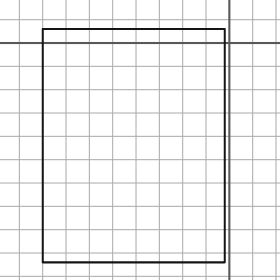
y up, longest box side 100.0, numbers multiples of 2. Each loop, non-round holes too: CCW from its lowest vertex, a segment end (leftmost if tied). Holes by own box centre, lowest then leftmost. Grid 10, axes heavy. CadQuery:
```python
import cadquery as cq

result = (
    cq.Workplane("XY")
    .moveTo(-80.0, -94.0)
    .lineTo(-2.0, -94.0)
    .lineTo(-2.0, 6.0)
    .lineTo(-80.0, 6.0)
    .close()
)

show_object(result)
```